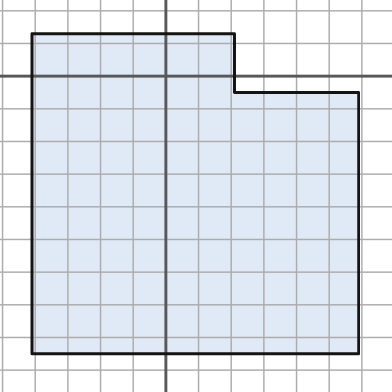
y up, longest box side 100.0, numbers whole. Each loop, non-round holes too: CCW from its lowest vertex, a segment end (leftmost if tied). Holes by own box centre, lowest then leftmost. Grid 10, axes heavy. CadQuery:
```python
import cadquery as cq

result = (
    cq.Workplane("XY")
    .moveTo(-41.0, -85.0)
    .lineTo(59.0, -85.0)
    .lineTo(59.0, -5.0)
    .lineTo(21.0, -5.0)
    .lineTo(21.0, 13.0)
    .lineTo(-41.0, 13.0)
    .close()
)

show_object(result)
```